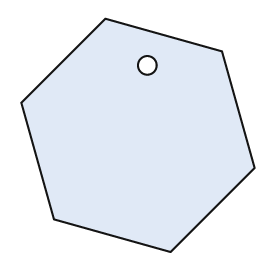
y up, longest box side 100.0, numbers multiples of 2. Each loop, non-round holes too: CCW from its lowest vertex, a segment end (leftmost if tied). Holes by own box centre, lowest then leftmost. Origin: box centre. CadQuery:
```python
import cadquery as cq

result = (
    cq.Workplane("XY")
    .moveTo(14.0, -50.0)
    .lineTo(50.0, -14.0)
    .lineTo(36.0, 36.0)
    .lineTo(-14.0, 50.0)
    .lineTo(-50.0, 14.0)
    .lineTo(-36.0, -36.0)
    .close()
    .moveTo(4.0, 30.0)
    .circle(4.0)
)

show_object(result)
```